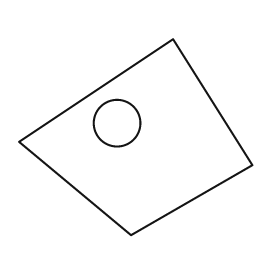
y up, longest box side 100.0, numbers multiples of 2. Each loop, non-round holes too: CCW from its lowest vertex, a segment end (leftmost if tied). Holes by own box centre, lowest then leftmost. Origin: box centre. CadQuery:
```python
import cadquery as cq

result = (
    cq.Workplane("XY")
    .moveTo(-2.0, -42.0)
    .lineTo(50.0, -12.0)
    .lineTo(16.0, 42.0)
    .lineTo(-50.0, -2.0)
    .close()
    .moveTo(-8.0, 6.0)
    .circle(10.0)
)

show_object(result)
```